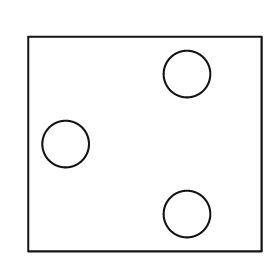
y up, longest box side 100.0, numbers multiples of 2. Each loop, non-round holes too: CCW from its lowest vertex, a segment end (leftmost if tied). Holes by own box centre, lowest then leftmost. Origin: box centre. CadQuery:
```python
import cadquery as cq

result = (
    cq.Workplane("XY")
    .moveTo(-50.0, -46.0)
    .lineTo(50.0, -46.0)
    .lineTo(50.0, 46.0)
    .lineTo(-50.0, 46.0)
    .close()
    .moveTo(18.0, -30.0)
    .circle(10.0)
    .moveTo(-34.0, 0.0)
    .circle(10.0)
    .moveTo(18.0, 30.0)
    .circle(10.0)
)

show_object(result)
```